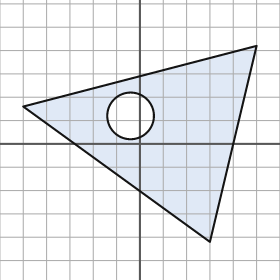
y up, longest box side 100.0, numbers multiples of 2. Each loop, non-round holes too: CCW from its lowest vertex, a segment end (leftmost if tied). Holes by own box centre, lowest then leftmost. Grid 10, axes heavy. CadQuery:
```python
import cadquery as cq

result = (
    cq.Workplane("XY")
    .moveTo(30.0, -42.0)
    .lineTo(50.0, 42.0)
    .lineTo(-50.0, 16.0)
    .close()
    .moveTo(-4.0, 12.0)
    .circle(10.0)
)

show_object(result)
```